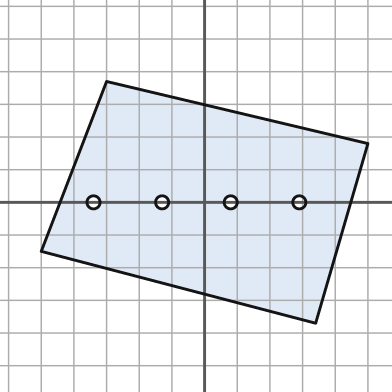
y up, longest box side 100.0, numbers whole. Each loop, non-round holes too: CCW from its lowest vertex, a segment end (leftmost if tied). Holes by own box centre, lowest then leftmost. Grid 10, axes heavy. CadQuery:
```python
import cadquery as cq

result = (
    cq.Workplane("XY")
    .moveTo(34.0, -37.0)
    .lineTo(50.0, 18.0)
    .lineTo(-30.0, 37.0)
    .lineTo(-50.0, -15.0)
    .close()
    .moveTo(-34.0, 0.0)
    .circle(2.0)
    .moveTo(-13.0, 0.0)
    .circle(2.0)
    .moveTo(8.0, 0.0)
    .circle(2.0)
    .moveTo(29.0, 0.0)
    .circle(2.0)
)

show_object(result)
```